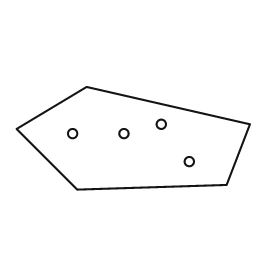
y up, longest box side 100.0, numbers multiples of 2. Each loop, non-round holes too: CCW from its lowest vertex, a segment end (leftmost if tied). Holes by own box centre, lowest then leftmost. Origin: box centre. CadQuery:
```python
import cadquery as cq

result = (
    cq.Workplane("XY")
    .moveTo(-24.0, -22.0)
    .lineTo(40.0, -20.0)
    .lineTo(50.0, 6.0)
    .lineTo(-20.0, 22.0)
    .lineTo(-50.0, 4.0)
    .close()
    .moveTo(24.0, -10.0)
    .circle(2.0)
    .moveTo(-26.0, 2.0)
    .circle(2.0)
    .moveTo(-4.0, 2.0)
    .circle(2.0)
    .moveTo(12.0, 6.0)
    .circle(2.0)
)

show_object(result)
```